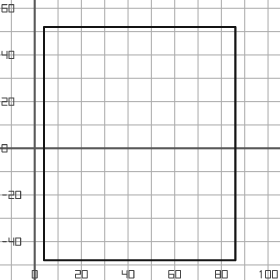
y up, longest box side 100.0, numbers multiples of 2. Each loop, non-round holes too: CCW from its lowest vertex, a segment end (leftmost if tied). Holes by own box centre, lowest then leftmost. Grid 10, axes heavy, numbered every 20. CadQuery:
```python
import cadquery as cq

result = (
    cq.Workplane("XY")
    .moveTo(4.0, -48.0)
    .lineTo(86.0, -48.0)
    .lineTo(86.0, 52.0)
    .lineTo(4.0, 52.0)
    .close()
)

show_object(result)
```